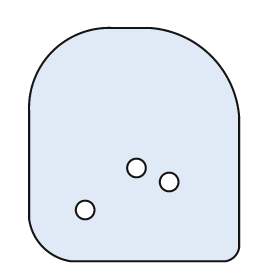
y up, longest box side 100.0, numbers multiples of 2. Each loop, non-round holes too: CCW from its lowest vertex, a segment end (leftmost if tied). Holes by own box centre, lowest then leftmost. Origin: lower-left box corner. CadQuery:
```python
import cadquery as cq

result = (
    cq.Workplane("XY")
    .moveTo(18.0, 0.0)
    .lineTo(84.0, 0.0)
    .threePointArc((88.0, 2.0), (90.0, 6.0))
    .lineTo(90.0, 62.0)
    .threePointArc((78.0, 88.0), (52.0, 100.0))
    .lineTo(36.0, 100.0)
    .threePointArc((10.0, 90.0), (0.0, 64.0))
    .lineTo(0.0, 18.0)
    .threePointArc((6.0, 6.0), (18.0, 0.0))
    .close()
    .moveTo(24.0, 22.0)
    .circle(4.0)
    .moveTo(60.0, 34.0)
    .circle(4.0)
    .moveTo(46.0, 40.0)
    .circle(4.0)
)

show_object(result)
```